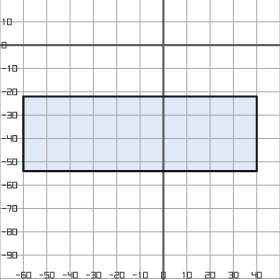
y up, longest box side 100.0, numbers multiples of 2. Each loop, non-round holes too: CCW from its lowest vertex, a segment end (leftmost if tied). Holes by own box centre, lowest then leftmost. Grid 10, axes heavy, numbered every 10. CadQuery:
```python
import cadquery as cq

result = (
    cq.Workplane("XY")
    .moveTo(-60.0, -54.0)
    .lineTo(40.0, -54.0)
    .lineTo(40.0, -22.0)
    .lineTo(-60.0, -22.0)
    .close()
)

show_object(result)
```